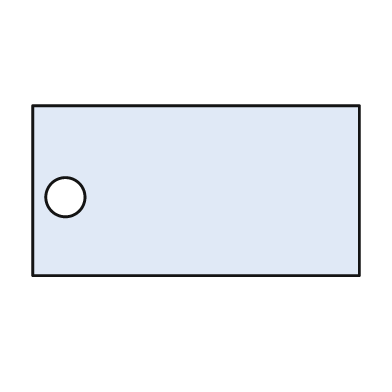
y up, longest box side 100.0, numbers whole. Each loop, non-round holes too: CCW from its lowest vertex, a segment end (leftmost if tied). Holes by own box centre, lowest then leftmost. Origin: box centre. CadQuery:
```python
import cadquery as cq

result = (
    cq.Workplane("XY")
    .moveTo(-50.0, -26.0)
    .lineTo(50.0, -26.0)
    .lineTo(50.0, 26.0)
    .lineTo(-50.0, 26.0)
    .close()
    .moveTo(-40.0, -2.0)
    .circle(6.0)
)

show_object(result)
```